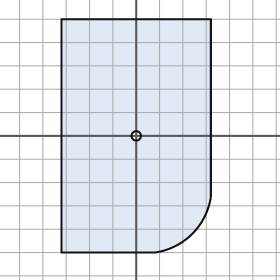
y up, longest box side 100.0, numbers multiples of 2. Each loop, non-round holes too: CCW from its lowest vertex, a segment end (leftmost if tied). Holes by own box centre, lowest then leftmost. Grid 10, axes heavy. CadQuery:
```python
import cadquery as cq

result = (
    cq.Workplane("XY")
    .moveTo(-32.0, -50.0)
    .lineTo(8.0, -50.0)
    .threePointArc((24.0, -42.0), (32.0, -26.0))
    .lineTo(32.0, 50.0)
    .lineTo(-32.0, 50.0)
    .close()
    .moveTo(0.0, 0.0)
    .circle(2.0)
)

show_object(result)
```